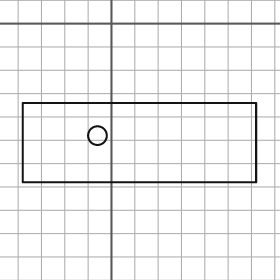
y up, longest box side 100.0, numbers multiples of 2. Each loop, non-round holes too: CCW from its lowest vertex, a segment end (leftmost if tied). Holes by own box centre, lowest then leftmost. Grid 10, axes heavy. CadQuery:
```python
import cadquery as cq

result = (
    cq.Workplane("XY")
    .moveTo(-38.0, -68.0)
    .lineTo(62.0, -68.0)
    .lineTo(62.0, -34.0)
    .lineTo(-38.0, -34.0)
    .close()
    .moveTo(-6.0, -48.0)
    .circle(4.0)
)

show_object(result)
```